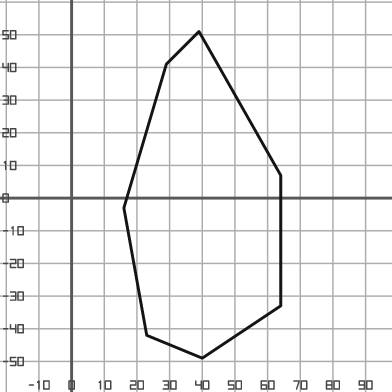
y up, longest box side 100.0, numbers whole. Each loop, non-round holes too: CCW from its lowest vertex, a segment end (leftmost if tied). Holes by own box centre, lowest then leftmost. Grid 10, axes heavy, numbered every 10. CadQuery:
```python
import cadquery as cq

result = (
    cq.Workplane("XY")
    .moveTo(40.0, -49.0)
    .lineTo(64.0, -33.0)
    .lineTo(64.0, 7.0)
    .lineTo(39.0, 51.0)
    .lineTo(29.0, 41.0)
    .lineTo(16.0, -3.0)
    .lineTo(23.0, -42.0)
    .close()
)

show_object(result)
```